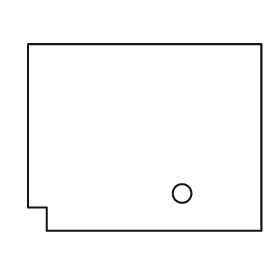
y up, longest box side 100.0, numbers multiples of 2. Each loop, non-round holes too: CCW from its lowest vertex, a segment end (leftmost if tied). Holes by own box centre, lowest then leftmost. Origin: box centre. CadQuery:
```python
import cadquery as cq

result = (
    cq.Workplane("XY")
    .moveTo(-42.0, -40.0)
    .lineTo(50.0, -40.0)
    .lineTo(50.0, 40.0)
    .lineTo(-50.0, 40.0)
    .lineTo(-50.0, -30.0)
    .lineTo(-42.0, -30.0)
    .close()
    .moveTo(16.0, -24.0)
    .circle(4.0)
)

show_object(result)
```